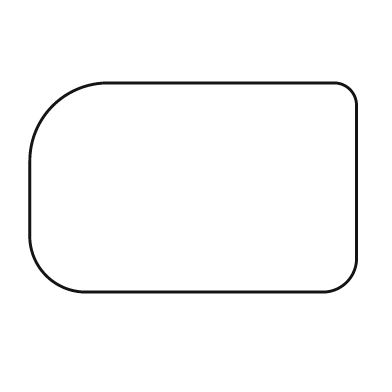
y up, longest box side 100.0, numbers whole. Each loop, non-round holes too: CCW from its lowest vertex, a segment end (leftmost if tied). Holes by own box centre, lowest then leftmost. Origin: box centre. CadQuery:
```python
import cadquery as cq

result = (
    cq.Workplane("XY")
    .moveTo(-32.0, -32.0)
    .lineTo(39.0, -32.0)
    .threePointArc((47.0, -29.0), (50.0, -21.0))
    .lineTo(50.0, 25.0)
    .threePointArc((48.0, 30.0), (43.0, 32.0))
    .lineTo(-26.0, 32.0)
    .threePointArc((-43.0, 25.0), (-50.0, 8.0))
    .lineTo(-50.0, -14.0)
    .threePointArc((-45.0, -27.0), (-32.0, -32.0))
    .close()
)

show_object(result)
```